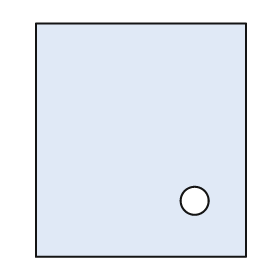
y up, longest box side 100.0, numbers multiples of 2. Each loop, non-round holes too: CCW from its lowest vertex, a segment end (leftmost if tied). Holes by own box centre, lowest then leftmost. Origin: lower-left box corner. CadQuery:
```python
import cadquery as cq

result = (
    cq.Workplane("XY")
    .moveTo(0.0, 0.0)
    .lineTo(90.0, 0.0)
    .lineTo(90.0, 100.0)
    .lineTo(0.0, 100.0)
    .close()
    .moveTo(68.0, 24.0)
    .circle(6.0)
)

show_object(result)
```